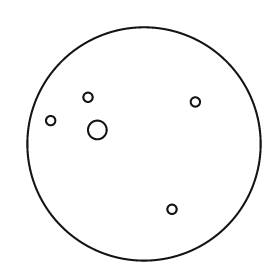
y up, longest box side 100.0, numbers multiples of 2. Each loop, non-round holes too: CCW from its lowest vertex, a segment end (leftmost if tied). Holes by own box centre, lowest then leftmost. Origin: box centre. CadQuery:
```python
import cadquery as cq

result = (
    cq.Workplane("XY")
    .moveTo(0.0, 0.0)
    .circle(50.0)
    .moveTo(12.0, -28.0)
    .circle(2.0)
    .moveTo(-20.0, 6.0)
    .circle(4.0)
    .moveTo(-40.0, 10.0)
    .circle(2.0)
    .moveTo(22.0, 18.0)
    .circle(2.0)
    .moveTo(-24.0, 20.0)
    .circle(2.0)
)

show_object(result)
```